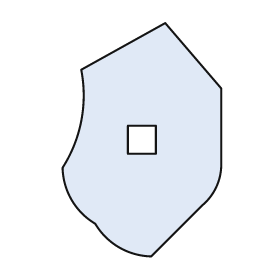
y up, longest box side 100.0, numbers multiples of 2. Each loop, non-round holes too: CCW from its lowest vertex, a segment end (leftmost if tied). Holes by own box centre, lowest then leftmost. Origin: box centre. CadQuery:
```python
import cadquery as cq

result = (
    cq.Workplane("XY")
    .moveTo(4.0, -50.0)
    .lineTo(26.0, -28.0)
    .threePointArc((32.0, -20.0), (34.0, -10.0))
    .lineTo(34.0, 22.0)
    .lineTo(10.0, 50.0)
    .lineTo(-26.0, 30.0)
    .threePointArc((-26.0, 8.0), (-34.0, -12.0))
    .threePointArc((-30.0, -26.0), (-20.0, -36.0))
    .threePointArc((-10.0, -46.0), (4.0, -50.0))
    .close()
    .moveTo(-6.0, -6.0)
    .lineTo(6.0, -6.0)
    .lineTo(6.0, 6.0)
    .lineTo(-6.0, 6.0)
    .close()
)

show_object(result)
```